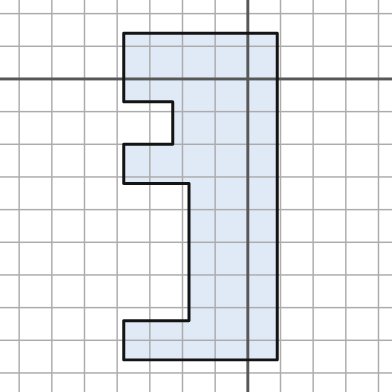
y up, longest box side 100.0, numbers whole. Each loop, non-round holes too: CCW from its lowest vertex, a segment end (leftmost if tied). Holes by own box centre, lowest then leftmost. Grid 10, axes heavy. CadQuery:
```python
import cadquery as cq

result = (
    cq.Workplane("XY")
    .moveTo(-38.0, -86.0)
    .lineTo(9.0, -86.0)
    .lineTo(9.0, 14.0)
    .lineTo(-38.0, 14.0)
    .lineTo(-38.0, -7.0)
    .lineTo(-23.0, -7.0)
    .lineTo(-23.0, -20.0)
    .lineTo(-38.0, -20.0)
    .lineTo(-38.0, -32.0)
    .lineTo(-18.0, -32.0)
    .lineTo(-18.0, -74.0)
    .lineTo(-38.0, -74.0)
    .close()
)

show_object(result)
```